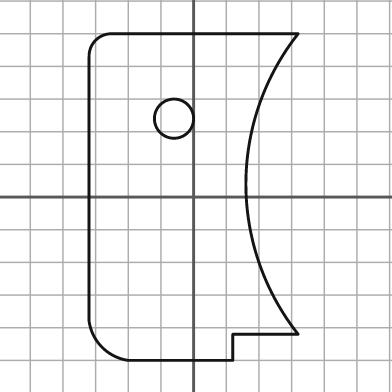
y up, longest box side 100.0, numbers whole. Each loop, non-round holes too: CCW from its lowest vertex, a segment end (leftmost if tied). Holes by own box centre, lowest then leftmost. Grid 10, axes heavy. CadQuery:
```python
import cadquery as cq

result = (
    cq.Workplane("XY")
    .moveTo(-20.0, -50.0)
    .lineTo(12.0, -50.0)
    .lineTo(12.0, -42.0)
    .lineTo(32.0, -42.0)
    .threePointArc((16.0, 4.0), (32.0, 50.0))
    .lineTo(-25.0, 50.0)
    .threePointArc((-30.0, 48.0), (-32.0, 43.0))
    .lineTo(-32.0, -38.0)
    .threePointArc((-28.0, -46.0), (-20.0, -50.0))
    .close()
    .moveTo(-6.0, 24.0)
    .circle(6.0)
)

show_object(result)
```